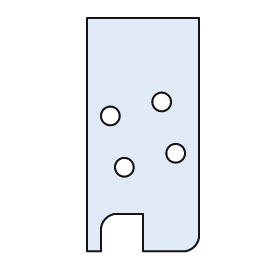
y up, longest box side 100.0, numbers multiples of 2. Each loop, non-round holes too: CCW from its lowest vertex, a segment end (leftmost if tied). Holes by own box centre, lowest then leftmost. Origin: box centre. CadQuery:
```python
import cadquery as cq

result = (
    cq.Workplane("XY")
    .moveTo(-24.0, -50.0)
    .lineTo(-18.0, -50.0)
    .lineTo(-18.0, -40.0)
    .threePointArc((-16.0, -36.0), (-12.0, -34.0))
    .lineTo(0.0, -34.0)
    .lineTo(0.0, -50.0)
    .lineTo(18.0, -50.0)
    .threePointArc((22.0, -48.0), (24.0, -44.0))
    .lineTo(24.0, 50.0)
    .lineTo(-24.0, 50.0)
    .close()
    .moveTo(-8.0, -14.0)
    .circle(4.0)
    .moveTo(14.0, -8.0)
    .circle(4.0)
    .moveTo(-14.0, 8.0)
    .circle(4.0)
    .moveTo(8.0, 14.0)
    .circle(4.0)
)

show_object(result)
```